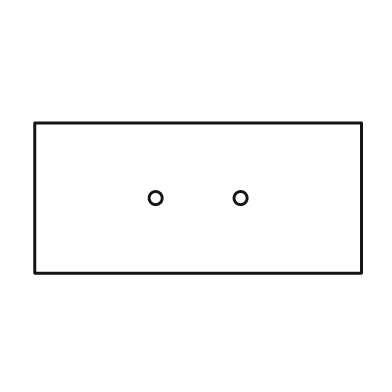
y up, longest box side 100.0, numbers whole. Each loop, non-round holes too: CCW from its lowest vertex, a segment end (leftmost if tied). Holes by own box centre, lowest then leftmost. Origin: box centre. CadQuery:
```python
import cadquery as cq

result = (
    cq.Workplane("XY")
    .moveTo(-50.0, -23.0)
    .lineTo(50.0, -23.0)
    .lineTo(50.0, 23.0)
    .lineTo(-50.0, 23.0)
    .close()
    .moveTo(-13.0, 0.0)
    .circle(2.0)
    .moveTo(13.0, 0.0)
    .circle(2.0)
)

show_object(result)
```